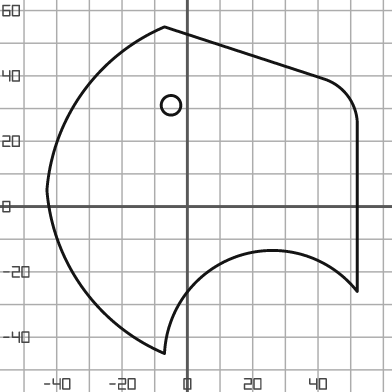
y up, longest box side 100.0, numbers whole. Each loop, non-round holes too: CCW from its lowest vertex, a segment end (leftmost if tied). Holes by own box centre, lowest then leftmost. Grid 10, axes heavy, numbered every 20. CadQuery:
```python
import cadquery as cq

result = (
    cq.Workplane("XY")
    .moveTo(-7.0, -45.0)
    .threePointArc((16.0, -15.0), (52.0, -26.0))
    .lineTo(52.0, 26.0)
    .threePointArc((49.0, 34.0), (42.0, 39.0))
    .lineTo(-7.0, 55.0)
    .threePointArc((-32.0, 35.0), (-43.0, 5.0))
    .threePointArc((-32.0, -25.0), (-7.0, -45.0))
    .close()
    .moveTo(-5.0, 31.0)
    .circle(3.0)
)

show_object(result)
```